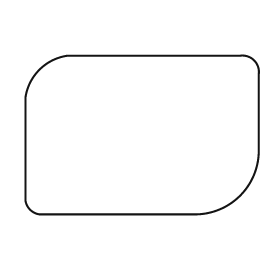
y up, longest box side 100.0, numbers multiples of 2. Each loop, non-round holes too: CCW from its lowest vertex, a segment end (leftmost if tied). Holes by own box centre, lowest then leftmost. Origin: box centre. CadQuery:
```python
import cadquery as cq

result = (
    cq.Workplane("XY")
    .moveTo(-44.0, -34.0)
    .lineTo(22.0, -34.0)
    .threePointArc((42.0, -26.0), (50.0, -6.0))
    .lineTo(50.0, 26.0)
    .threePointArc((48.0, 32.0), (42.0, 34.0))
    .lineTo(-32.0, 34.0)
    .threePointArc((-44.0, 28.0), (-50.0, 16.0))
    .lineTo(-50.0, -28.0)
    .threePointArc((-48.0, -32.0), (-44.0, -34.0))
    .close()
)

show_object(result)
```